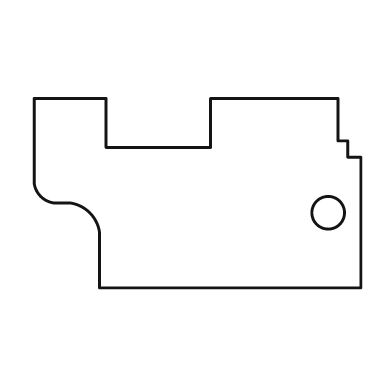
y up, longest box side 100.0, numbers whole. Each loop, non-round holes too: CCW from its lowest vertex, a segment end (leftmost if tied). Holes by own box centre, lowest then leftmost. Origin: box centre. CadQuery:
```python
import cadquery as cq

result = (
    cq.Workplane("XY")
    .moveTo(-30.0, -29.0)
    .lineTo(50.0, -29.0)
    .lineTo(50.0, 11.0)
    .lineTo(46.0, 11.0)
    .lineTo(46.0, 16.0)
    .lineTo(43.0, 16.0)
    .lineTo(43.0, 29.0)
    .lineTo(4.0, 29.0)
    .lineTo(4.0, 14.0)
    .lineTo(-28.0, 14.0)
    .lineTo(-28.0, 29.0)
    .lineTo(-50.0, 29.0)
    .lineTo(-50.0, 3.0)
    .threePointArc((-48.0, -1.0), (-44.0, -3.0))
    .lineTo(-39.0, -3.0)
    .threePointArc((-33.0, -6.0), (-30.0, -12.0))
    .close()
    .moveTo(40.0, -6.0)
    .circle(5.0)
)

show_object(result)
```